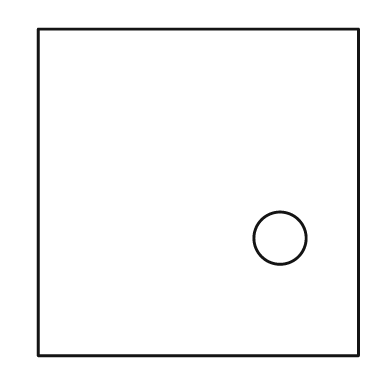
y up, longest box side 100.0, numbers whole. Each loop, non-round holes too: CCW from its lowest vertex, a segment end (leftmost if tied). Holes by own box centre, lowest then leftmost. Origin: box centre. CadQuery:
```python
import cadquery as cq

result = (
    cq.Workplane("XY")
    .moveTo(-49.0, -50.0)
    .lineTo(49.0, -50.0)
    .lineTo(49.0, 50.0)
    .lineTo(-49.0, 50.0)
    .close()
    .moveTo(25.0, -14.0)
    .circle(8.0)
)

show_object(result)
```